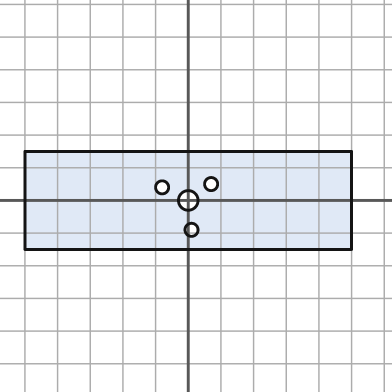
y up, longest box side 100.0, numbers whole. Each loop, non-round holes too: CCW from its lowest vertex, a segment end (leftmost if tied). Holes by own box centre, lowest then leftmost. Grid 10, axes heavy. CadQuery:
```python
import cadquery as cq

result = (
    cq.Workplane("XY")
    .moveTo(-50.0, -15.0)
    .lineTo(50.0, -15.0)
    .lineTo(50.0, 15.0)
    .lineTo(-50.0, 15.0)
    .close()
    .moveTo(1.0, -9.0)
    .circle(2.0)
    .moveTo(0.0, 0.0)
    .circle(3.0)
    .moveTo(-8.0, 4.0)
    .circle(2.0)
    .moveTo(7.0, 5.0)
    .circle(2.0)
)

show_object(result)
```